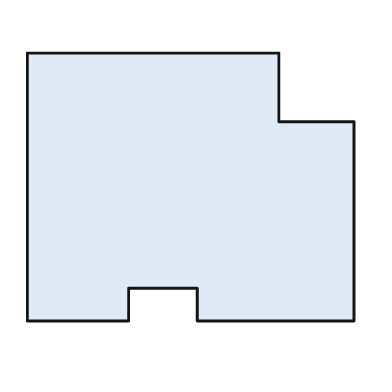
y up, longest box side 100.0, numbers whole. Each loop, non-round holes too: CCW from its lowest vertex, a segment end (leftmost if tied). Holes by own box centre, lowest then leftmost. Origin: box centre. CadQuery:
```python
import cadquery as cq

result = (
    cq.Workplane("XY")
    .moveTo(-50.0, -41.0)
    .lineTo(-19.0, -41.0)
    .lineTo(-19.0, -31.0)
    .lineTo(2.0, -31.0)
    .lineTo(2.0, -41.0)
    .lineTo(50.0, -41.0)
    .lineTo(50.0, 20.0)
    .lineTo(27.0, 20.0)
    .lineTo(27.0, 41.0)
    .lineTo(-50.0, 41.0)
    .close()
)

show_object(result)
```